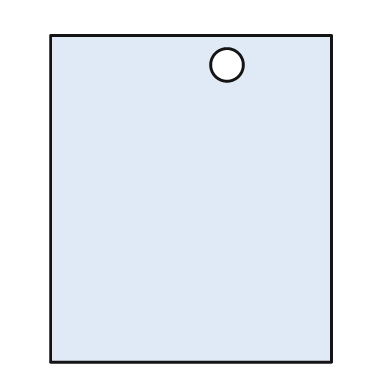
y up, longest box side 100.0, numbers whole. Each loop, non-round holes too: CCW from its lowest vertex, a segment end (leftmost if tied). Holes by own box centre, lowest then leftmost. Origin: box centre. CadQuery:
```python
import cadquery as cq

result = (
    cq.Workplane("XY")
    .moveTo(-43.0, -50.0)
    .lineTo(43.0, -50.0)
    .lineTo(43.0, 50.0)
    .lineTo(-43.0, 50.0)
    .close()
    .moveTo(11.0, 41.0)
    .circle(5.0)
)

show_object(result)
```